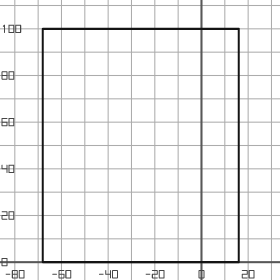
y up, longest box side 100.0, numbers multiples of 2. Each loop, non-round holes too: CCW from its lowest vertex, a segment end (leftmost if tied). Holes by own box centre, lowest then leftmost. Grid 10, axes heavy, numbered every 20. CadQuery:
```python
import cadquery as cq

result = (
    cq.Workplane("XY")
    .moveTo(-68.0, 0.0)
    .lineTo(16.0, 0.0)
    .lineTo(16.0, 100.0)
    .lineTo(-68.0, 100.0)
    .close()
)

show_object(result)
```